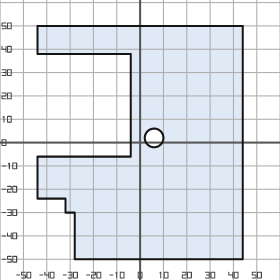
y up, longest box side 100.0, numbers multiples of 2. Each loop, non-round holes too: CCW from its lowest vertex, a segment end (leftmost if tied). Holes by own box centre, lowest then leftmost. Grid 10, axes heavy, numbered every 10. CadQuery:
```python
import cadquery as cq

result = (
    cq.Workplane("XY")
    .moveTo(-28.0, -50.0)
    .lineTo(44.0, -50.0)
    .lineTo(44.0, 50.0)
    .lineTo(-44.0, 50.0)
    .lineTo(-44.0, 38.0)
    .lineTo(-4.0, 38.0)
    .lineTo(-4.0, -6.0)
    .lineTo(-44.0, -6.0)
    .lineTo(-44.0, -24.0)
    .lineTo(-32.0, -24.0)
    .lineTo(-32.0, -30.0)
    .lineTo(-28.0, -30.0)
    .close()
    .moveTo(6.0, 2.0)
    .circle(4.0)
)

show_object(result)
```